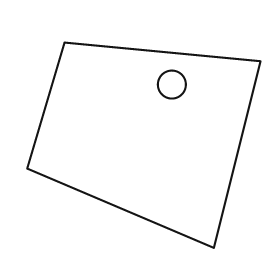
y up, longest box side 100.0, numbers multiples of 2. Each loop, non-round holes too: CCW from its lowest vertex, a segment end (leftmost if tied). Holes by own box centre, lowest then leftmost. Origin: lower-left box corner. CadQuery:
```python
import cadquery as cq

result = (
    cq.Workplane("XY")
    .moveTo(80.0, 0.0)
    .lineTo(100.0, 80.0)
    .lineTo(16.0, 88.0)
    .lineTo(0.0, 34.0)
    .close()
    .moveTo(62.0, 70.0)
    .circle(6.0)
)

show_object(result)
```